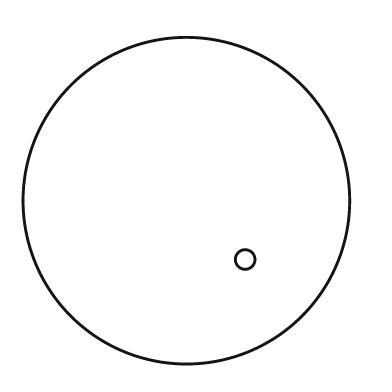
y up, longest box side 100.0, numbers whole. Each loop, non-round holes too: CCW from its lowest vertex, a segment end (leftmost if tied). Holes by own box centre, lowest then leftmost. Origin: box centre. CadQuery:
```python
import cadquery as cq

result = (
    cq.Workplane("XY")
    .moveTo(0.0, 0.0)
    .circle(50.0)
    .moveTo(18.0, -18.0)
    .circle(3.0)
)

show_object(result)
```